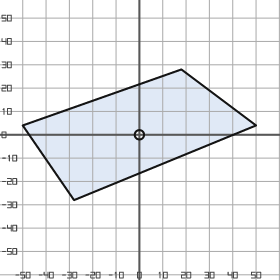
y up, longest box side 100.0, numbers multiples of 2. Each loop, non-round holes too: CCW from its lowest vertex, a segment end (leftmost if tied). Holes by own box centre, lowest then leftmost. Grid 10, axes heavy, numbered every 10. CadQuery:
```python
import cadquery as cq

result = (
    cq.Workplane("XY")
    .moveTo(-28.0, -28.0)
    .lineTo(50.0, 4.0)
    .lineTo(18.0, 28.0)
    .lineTo(-50.0, 4.0)
    .close()
    .moveTo(0.0, 0.0)
    .circle(2.0)
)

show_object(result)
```